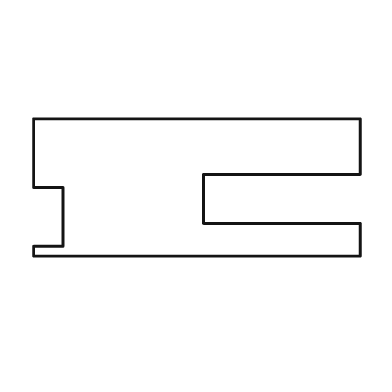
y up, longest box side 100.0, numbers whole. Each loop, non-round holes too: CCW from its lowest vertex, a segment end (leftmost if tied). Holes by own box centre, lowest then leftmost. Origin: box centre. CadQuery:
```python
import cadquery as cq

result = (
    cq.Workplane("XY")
    .moveTo(-50.0, -21.0)
    .lineTo(50.0, -21.0)
    .lineTo(50.0, -11.0)
    .lineTo(2.0, -11.0)
    .lineTo(2.0, 4.0)
    .lineTo(50.0, 4.0)
    .lineTo(50.0, 21.0)
    .lineTo(-50.0, 21.0)
    .lineTo(-50.0, 0.0)
    .lineTo(-41.0, 0.0)
    .lineTo(-41.0, -18.0)
    .lineTo(-50.0, -18.0)
    .close()
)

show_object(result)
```